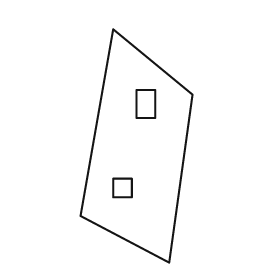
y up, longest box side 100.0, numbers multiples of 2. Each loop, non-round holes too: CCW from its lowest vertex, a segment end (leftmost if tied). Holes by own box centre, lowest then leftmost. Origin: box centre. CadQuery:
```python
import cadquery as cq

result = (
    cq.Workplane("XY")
    .moveTo(14.0, -50.0)
    .lineTo(24.0, 22.0)
    .lineTo(-10.0, 50.0)
    .lineTo(-24.0, -30.0)
    .close()
    .moveTo(-10.0, -22.0)
    .lineTo(-2.0, -22.0)
    .lineTo(-2.0, -14.0)
    .lineTo(-10.0, -14.0)
    .close()
    .moveTo(0.0, 12.0)
    .lineTo(8.0, 12.0)
    .lineTo(8.0, 24.0)
    .lineTo(0.0, 24.0)
    .close()
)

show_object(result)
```